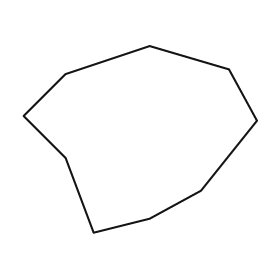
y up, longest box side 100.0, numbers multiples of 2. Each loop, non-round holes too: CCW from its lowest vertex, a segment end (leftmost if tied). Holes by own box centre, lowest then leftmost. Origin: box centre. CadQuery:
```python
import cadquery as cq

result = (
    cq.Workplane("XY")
    .moveTo(-20.0, -40.0)
    .lineTo(4.0, -34.0)
    .lineTo(26.0, -22.0)
    .lineTo(50.0, 8.0)
    .lineTo(38.0, 30.0)
    .lineTo(4.0, 40.0)
    .lineTo(-32.0, 28.0)
    .lineTo(-50.0, 10.0)
    .lineTo(-32.0, -8.0)
    .close()
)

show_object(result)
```